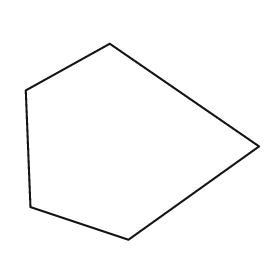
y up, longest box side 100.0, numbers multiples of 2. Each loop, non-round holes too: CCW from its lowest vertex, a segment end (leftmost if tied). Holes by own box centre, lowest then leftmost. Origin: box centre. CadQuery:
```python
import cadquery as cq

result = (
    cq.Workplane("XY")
    .moveTo(-6.0, -42.0)
    .lineTo(50.0, -2.0)
    .lineTo(-14.0, 42.0)
    .lineTo(-50.0, 22.0)
    .lineTo(-48.0, -28.0)
    .close()
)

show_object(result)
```